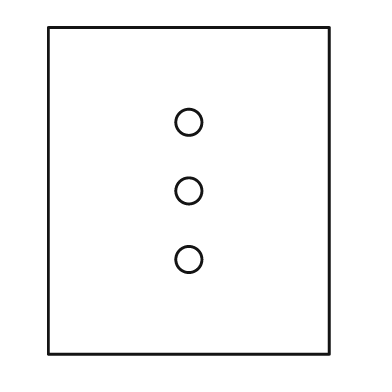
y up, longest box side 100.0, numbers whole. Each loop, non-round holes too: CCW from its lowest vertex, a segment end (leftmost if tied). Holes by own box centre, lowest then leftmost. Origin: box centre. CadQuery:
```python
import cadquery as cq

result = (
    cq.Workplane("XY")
    .moveTo(-43.0, -50.0)
    .lineTo(43.0, -50.0)
    .lineTo(43.0, 50.0)
    .lineTo(-43.0, 50.0)
    .close()
    .moveTo(0.0, -21.0)
    .circle(4.0)
    .moveTo(0.0, 0.0)
    .circle(4.0)
    .moveTo(0.0, 21.0)
    .circle(4.0)
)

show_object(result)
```